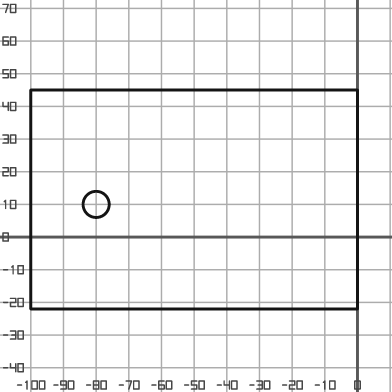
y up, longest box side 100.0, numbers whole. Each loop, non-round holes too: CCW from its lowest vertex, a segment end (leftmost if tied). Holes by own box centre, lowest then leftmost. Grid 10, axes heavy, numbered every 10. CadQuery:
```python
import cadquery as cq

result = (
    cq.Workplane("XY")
    .moveTo(-100.0, -22.0)
    .lineTo(0.0, -22.0)
    .lineTo(0.0, 45.0)
    .lineTo(-100.0, 45.0)
    .close()
    .moveTo(-80.0, 10.0)
    .circle(4.0)
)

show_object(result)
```